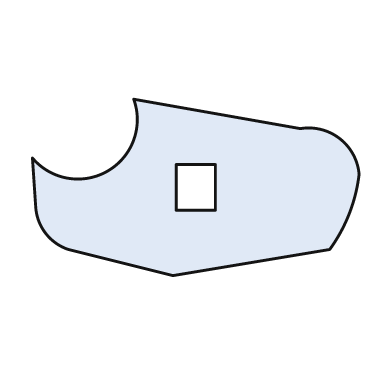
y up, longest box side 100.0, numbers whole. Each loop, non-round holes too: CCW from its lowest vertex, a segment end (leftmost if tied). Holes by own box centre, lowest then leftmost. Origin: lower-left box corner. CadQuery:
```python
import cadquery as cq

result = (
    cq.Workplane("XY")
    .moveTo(43.0, 0.0)
    .lineTo(91.0, 8.0)
    .threePointArc((97.0, 19.0), (100.0, 31.0))
    .threePointArc((94.0, 42.0), (82.0, 45.0))
    .lineTo(31.0, 54.0)
    .threePointArc((23.0, 32.0), (0.0, 36.0))
    .lineTo(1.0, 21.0)
    .threePointArc((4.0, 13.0), (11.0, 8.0))
    .close()
    .moveTo(44.0, 20.0)
    .lineTo(56.0, 20.0)
    .lineTo(56.0, 34.0)
    .lineTo(44.0, 34.0)
    .close()
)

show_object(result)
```